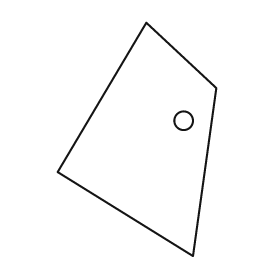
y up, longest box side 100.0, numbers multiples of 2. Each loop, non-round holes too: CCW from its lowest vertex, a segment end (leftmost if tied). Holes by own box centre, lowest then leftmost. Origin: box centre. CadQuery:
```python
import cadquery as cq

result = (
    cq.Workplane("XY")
    .moveTo(24.0, -50.0)
    .lineTo(34.0, 22.0)
    .lineTo(4.0, 50.0)
    .lineTo(-34.0, -14.0)
    .close()
    .moveTo(20.0, 8.0)
    .circle(4.0)
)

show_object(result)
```